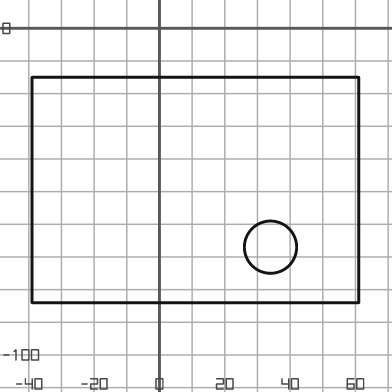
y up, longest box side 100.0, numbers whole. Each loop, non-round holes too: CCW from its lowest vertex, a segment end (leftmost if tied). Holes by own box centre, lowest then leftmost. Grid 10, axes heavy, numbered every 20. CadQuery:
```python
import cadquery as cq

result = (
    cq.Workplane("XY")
    .moveTo(-39.0, -84.0)
    .lineTo(61.0, -84.0)
    .lineTo(61.0, -15.0)
    .lineTo(-39.0, -15.0)
    .close()
    .moveTo(34.0, -67.0)
    .circle(8.0)
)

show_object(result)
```